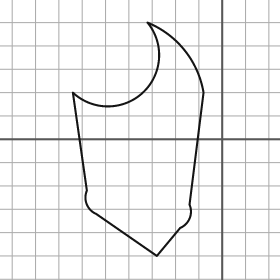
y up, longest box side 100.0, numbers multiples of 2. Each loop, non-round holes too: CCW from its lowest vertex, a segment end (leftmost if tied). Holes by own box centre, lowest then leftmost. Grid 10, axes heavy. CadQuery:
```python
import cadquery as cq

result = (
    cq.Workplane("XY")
    .moveTo(-28.0, -50.0)
    .lineTo(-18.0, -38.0)
    .threePointArc((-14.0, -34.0), (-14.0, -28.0))
    .lineTo(-8.0, 20.0)
    .threePointArc((-16.0, 38.0), (-32.0, 50.0))
    .threePointArc((-34.0, 20.0), (-64.0, 20.0))
    .lineTo(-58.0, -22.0)
    .threePointArc((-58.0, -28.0), (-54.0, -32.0))
    .close()
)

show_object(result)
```